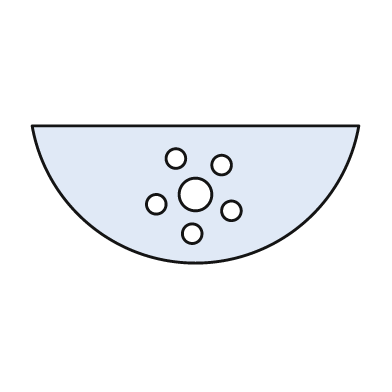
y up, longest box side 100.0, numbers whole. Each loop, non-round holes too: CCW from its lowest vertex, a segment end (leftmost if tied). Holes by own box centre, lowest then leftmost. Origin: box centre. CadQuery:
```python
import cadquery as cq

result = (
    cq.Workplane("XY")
    .moveTo(-50.0, 21.0)
    .threePointArc((0.0, -21.0), (50.0, 21.0))
    .close()
    .moveTo(-1.0, -12.0)
    .circle(3.0)
    .moveTo(11.0, -5.0)
    .circle(3.0)
    .moveTo(-12.0, -3.0)
    .circle(3.0)
    .moveTo(0.0, 0.0)
    .circle(5.0)
    .moveTo(8.0, 9.0)
    .circle(3.0)
    .moveTo(-6.0, 11.0)
    .circle(3.0)
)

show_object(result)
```